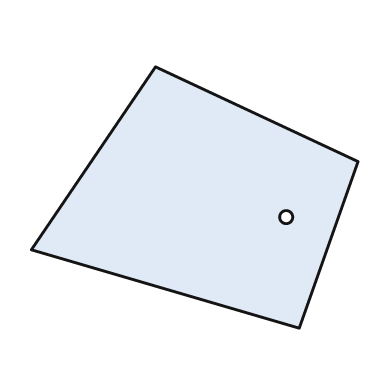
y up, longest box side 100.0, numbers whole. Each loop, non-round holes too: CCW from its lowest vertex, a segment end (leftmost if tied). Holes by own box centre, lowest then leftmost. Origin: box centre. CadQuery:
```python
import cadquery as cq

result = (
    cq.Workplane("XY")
    .moveTo(32.0, -40.0)
    .lineTo(50.0, 11.0)
    .lineTo(-12.0, 40.0)
    .lineTo(-50.0, -16.0)
    .close()
    .moveTo(28.0, -6.0)
    .circle(2.0)
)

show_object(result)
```